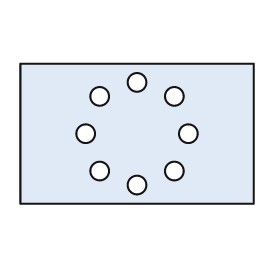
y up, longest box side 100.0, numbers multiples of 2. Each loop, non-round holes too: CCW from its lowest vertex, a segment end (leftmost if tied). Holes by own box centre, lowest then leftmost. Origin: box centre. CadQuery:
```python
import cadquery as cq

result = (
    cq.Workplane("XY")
    .moveTo(-50.0, -30.0)
    .lineTo(50.0, -30.0)
    .lineTo(50.0, 30.0)
    .lineTo(-50.0, 30.0)
    .close()
    .moveTo(0.0, -22.0)
    .circle(4.0)
    .moveTo(-16.0, -16.0)
    .circle(4.0)
    .moveTo(16.0, -16.0)
    .circle(4.0)
    .moveTo(-22.0, 0.0)
    .circle(4.0)
    .moveTo(22.0, 0.0)
    .circle(4.0)
    .moveTo(-16.0, 16.0)
    .circle(4.0)
    .moveTo(16.0, 16.0)
    .circle(4.0)
    .moveTo(0.0, 22.0)
    .circle(4.0)
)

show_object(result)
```